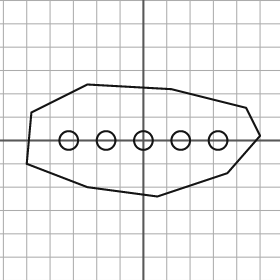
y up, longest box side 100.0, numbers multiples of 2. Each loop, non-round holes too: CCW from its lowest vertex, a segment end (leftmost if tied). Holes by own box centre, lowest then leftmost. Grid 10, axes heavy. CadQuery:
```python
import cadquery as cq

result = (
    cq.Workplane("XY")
    .moveTo(6.0, -24.0)
    .lineTo(36.0, -14.0)
    .lineTo(50.0, 2.0)
    .lineTo(44.0, 14.0)
    .lineTo(12.0, 22.0)
    .lineTo(-24.0, 24.0)
    .lineTo(-48.0, 12.0)
    .lineTo(-50.0, -10.0)
    .lineTo(-24.0, -20.0)
    .close()
    .moveTo(-32.0, 0.0)
    .circle(4.0)
    .moveTo(-16.0, 0.0)
    .circle(4.0)
    .moveTo(0.0, 0.0)
    .circle(4.0)
    .moveTo(16.0, 0.0)
    .circle(4.0)
    .moveTo(32.0, 0.0)
    .circle(4.0)
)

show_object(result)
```